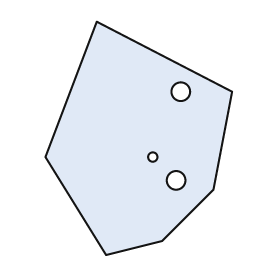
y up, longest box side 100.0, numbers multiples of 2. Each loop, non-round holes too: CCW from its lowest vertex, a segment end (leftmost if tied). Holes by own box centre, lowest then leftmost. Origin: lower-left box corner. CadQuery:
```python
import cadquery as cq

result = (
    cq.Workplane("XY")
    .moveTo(26.0, 0.0)
    .lineTo(50.0, 6.0)
    .lineTo(72.0, 28.0)
    .lineTo(80.0, 70.0)
    .lineTo(22.0, 100.0)
    .lineTo(0.0, 42.0)
    .close()
    .moveTo(56.0, 32.0)
    .circle(4.0)
    .moveTo(46.0, 42.0)
    .circle(2.0)
    .moveTo(58.0, 70.0)
    .circle(4.0)
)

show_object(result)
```